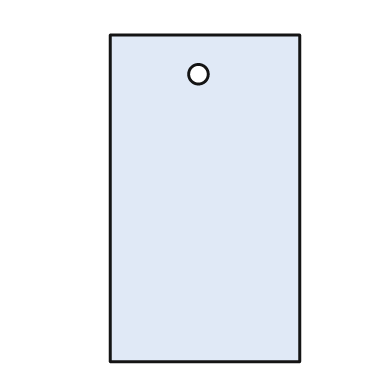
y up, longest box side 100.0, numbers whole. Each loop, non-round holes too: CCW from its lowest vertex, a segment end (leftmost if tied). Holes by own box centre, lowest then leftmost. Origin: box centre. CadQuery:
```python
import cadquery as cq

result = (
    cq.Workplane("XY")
    .moveTo(-29.0, -50.0)
    .lineTo(29.0, -50.0)
    .lineTo(29.0, 50.0)
    .lineTo(-29.0, 50.0)
    .close()
    .moveTo(-2.0, 38.0)
    .circle(3.0)
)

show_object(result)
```